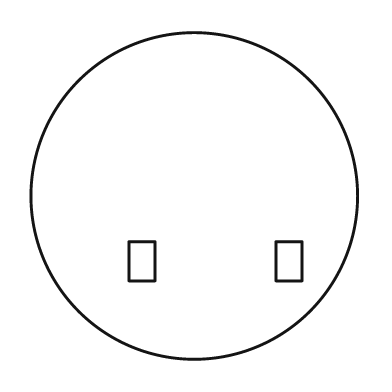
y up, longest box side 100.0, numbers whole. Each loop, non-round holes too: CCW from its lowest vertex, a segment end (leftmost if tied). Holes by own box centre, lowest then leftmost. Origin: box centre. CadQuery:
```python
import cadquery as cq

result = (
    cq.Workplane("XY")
    .moveTo(0.0, 0.0)
    .circle(50.0)
    .moveTo(-20.0, -26.0)
    .lineTo(-12.0, -26.0)
    .lineTo(-12.0, -14.0)
    .lineTo(-20.0, -14.0)
    .close()
    .moveTo(25.0, -26.0)
    .lineTo(33.0, -26.0)
    .lineTo(33.0, -14.0)
    .lineTo(25.0, -14.0)
    .close()
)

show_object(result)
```